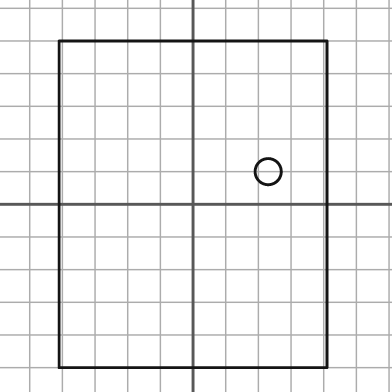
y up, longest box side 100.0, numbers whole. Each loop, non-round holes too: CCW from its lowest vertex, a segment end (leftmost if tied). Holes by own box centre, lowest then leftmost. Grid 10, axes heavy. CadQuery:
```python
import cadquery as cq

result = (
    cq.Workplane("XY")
    .moveTo(-41.0, -50.0)
    .lineTo(41.0, -50.0)
    .lineTo(41.0, 50.0)
    .lineTo(-41.0, 50.0)
    .close()
    .moveTo(23.0, 10.0)
    .circle(4.0)
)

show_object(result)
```